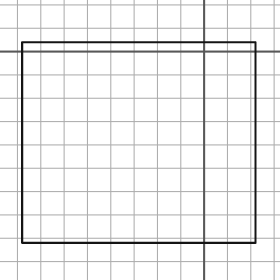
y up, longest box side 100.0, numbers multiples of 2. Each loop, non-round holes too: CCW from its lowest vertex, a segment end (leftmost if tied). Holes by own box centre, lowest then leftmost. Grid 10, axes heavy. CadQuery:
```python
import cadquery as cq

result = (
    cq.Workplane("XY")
    .moveTo(-78.0, -82.0)
    .lineTo(22.0, -82.0)
    .lineTo(22.0, 4.0)
    .lineTo(-78.0, 4.0)
    .close()
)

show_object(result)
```